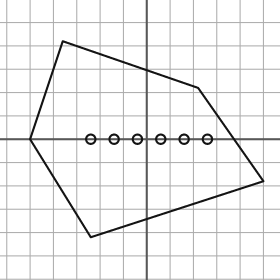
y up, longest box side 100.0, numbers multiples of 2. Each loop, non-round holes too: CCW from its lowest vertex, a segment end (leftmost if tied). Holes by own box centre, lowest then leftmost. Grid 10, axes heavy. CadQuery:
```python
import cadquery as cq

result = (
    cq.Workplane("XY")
    .moveTo(-24.0, -42.0)
    .lineTo(50.0, -18.0)
    .lineTo(22.0, 22.0)
    .lineTo(-36.0, 42.0)
    .lineTo(-50.0, 0.0)
    .close()
    .moveTo(-24.0, 0.0)
    .circle(2.0)
    .moveTo(-14.0, 0.0)
    .circle(2.0)
    .moveTo(-4.0, 0.0)
    .circle(2.0)
    .moveTo(6.0, 0.0)
    .circle(2.0)
    .moveTo(16.0, 0.0)
    .circle(2.0)
    .moveTo(26.0, 0.0)
    .circle(2.0)
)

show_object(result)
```